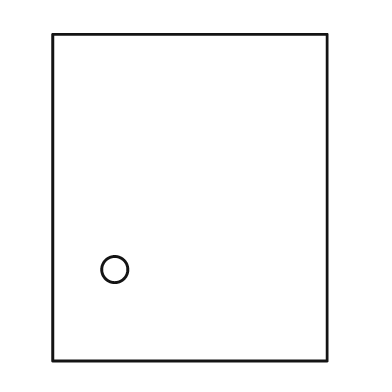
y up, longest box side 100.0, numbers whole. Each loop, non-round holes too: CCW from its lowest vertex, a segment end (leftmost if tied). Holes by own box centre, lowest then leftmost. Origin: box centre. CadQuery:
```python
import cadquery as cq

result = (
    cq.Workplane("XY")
    .moveTo(-42.0, -50.0)
    .lineTo(42.0, -50.0)
    .lineTo(42.0, 50.0)
    .lineTo(-42.0, 50.0)
    .close()
    .moveTo(-23.0, -22.0)
    .circle(4.0)
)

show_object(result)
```